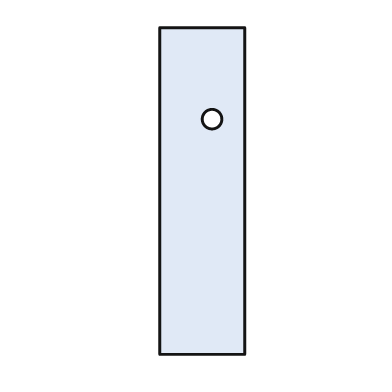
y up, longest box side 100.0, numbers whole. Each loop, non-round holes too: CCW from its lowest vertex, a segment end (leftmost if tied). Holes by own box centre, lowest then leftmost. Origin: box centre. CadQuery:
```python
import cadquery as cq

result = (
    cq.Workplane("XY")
    .moveTo(-13.0, -50.0)
    .lineTo(13.0, -50.0)
    .lineTo(13.0, 50.0)
    .lineTo(-13.0, 50.0)
    .close()
    .moveTo(3.0, 22.0)
    .circle(3.0)
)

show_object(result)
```